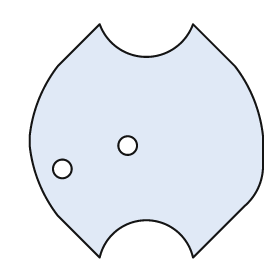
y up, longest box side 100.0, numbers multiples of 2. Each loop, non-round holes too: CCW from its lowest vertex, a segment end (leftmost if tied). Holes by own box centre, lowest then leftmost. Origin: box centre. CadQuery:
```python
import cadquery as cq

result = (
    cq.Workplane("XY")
    .moveTo(-20.0, -50.0)
    .threePointArc((0.0, -34.0), (20.0, -50.0))
    .lineTo(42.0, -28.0)
    .threePointArc((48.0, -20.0), (50.0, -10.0))
    .lineTo(50.0, 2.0)
    .threePointArc((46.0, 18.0), (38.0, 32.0))
    .lineTo(20.0, 50.0)
    .threePointArc((0.0, 36.0), (-20.0, 50.0))
    .lineTo(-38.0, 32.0)
    .threePointArc((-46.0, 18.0), (-50.0, 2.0))
    .lineTo(-50.0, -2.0)
    .threePointArc((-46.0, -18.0), (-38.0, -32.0))
    .close()
    .moveTo(-36.0, -12.0)
    .circle(4.0)
    .moveTo(-8.0, -2.0)
    .circle(4.0)
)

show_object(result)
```